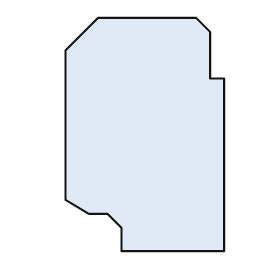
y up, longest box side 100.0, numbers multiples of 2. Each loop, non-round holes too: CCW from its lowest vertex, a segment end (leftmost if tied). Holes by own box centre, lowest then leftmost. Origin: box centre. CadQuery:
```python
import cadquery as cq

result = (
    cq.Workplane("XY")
    .moveTo(-10.0, -50.0)
    .lineTo(34.0, -50.0)
    .lineTo(34.0, 24.0)
    .lineTo(28.0, 24.0)
    .lineTo(28.0, 44.0)
    .lineTo(22.0, 50.0)
    .lineTo(-20.0, 50.0)
    .lineTo(-34.0, 36.0)
    .lineTo(-34.0, -28.0)
    .lineTo(-24.0, -34.0)
    .lineTo(-16.0, -34.0)
    .lineTo(-10.0, -40.0)
    .close()
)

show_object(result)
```